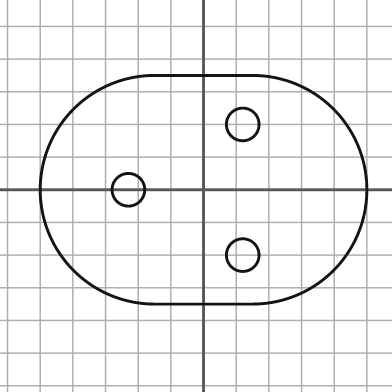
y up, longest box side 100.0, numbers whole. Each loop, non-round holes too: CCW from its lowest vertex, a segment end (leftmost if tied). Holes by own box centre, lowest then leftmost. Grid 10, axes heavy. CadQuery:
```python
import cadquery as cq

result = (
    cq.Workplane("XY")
    .moveTo(-15.0, -35.0)
    .lineTo(15.0, -35.0)
    .threePointArc((50.0, 0.0), (15.0, 35.0))
    .lineTo(-15.0, 35.0)
    .threePointArc((-50.0, 0.0), (-15.0, -35.0))
    .close()
    .moveTo(12.0, -20.0)
    .circle(5.0)
    .moveTo(-23.0, 0.0)
    .circle(5.0)
    .moveTo(12.0, 20.0)
    .circle(5.0)
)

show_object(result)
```